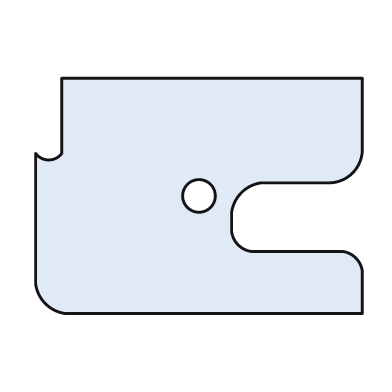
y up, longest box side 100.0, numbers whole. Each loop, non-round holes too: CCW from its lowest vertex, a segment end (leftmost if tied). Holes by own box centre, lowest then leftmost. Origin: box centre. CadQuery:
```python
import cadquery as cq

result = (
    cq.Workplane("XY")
    .moveTo(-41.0, -36.0)
    .lineTo(50.0, -36.0)
    .lineTo(50.0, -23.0)
    .threePointArc((48.0, -19.0), (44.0, -17.0))
    .lineTo(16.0, -17.0)
    .threePointArc((12.0, -15.0), (10.0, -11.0))
    .lineTo(10.0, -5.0)
    .threePointArc((13.0, 1.0), (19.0, 4.0))
    .lineTo(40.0, 4.0)
    .threePointArc((47.0, 7.0), (50.0, 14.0))
    .lineTo(50.0, 36.0)
    .lineTo(-42.0, 36.0)
    .lineTo(-42.0, 13.0)
    .threePointArc((-46.0, 11.0), (-50.0, 13.0))
    .lineTo(-50.0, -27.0)
    .threePointArc((-47.0, -33.0), (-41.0, -36.0))
    .close()
    .moveTo(0.0, 0.0)
    .circle(5.0)
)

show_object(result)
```